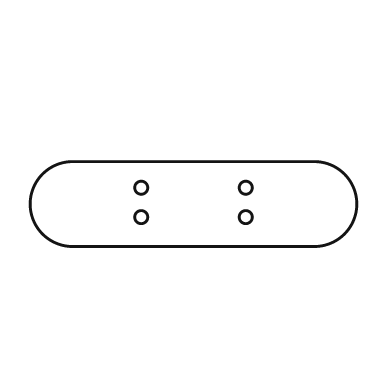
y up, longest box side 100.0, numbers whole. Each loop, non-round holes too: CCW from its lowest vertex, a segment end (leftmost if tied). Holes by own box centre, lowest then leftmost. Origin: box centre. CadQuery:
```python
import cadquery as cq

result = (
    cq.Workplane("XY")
    .moveTo(-37.0, -13.0)
    .lineTo(37.0, -13.0)
    .threePointArc((50.0, 0.0), (37.0, 13.0))
    .lineTo(-37.0, 13.0)
    .threePointArc((-50.0, 0.0), (-37.0, -13.0))
    .close()
    .moveTo(-16.0, -4.0)
    .circle(2.0)
    .moveTo(16.0, -4.0)
    .circle(2.0)
    .moveTo(-16.0, 5.0)
    .circle(2.0)
    .moveTo(16.0, 5.0)
    .circle(2.0)
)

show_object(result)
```